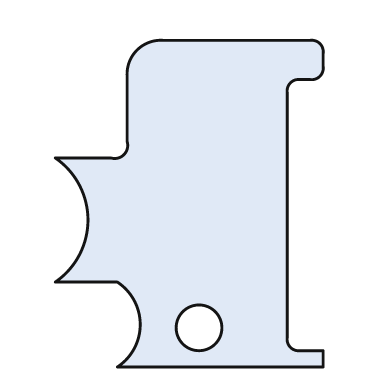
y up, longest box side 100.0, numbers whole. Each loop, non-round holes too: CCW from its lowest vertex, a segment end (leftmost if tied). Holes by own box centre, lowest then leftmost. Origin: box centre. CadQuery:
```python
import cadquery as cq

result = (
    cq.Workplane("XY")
    .moveTo(-22.0, -50.0)
    .lineTo(41.0, -50.0)
    .lineTo(41.0, -45.0)
    .lineTo(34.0, -45.0)
    .threePointArc((31.0, -44.0), (30.0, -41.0))
    .lineTo(30.0, 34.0)
    .threePointArc((31.0, 37.0), (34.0, 38.0))
    .lineTo(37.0, 38.0)
    .threePointArc((40.0, 39.0), (41.0, 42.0))
    .lineTo(41.0, 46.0)
    .threePointArc((40.0, 49.0), (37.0, 50.0))
    .lineTo(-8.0, 50.0)
    .threePointArc((-16.0, 47.0), (-19.0, 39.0))
    .lineTo(-19.0, 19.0)
    .threePointArc((-20.0, 15.0), (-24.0, 14.0))
    .lineTo(-41.0, 14.0)
    .threePointArc((-31.0, -5.0), (-41.0, -24.0))
    .lineTo(-22.0, -24.0)
    .threePointArc((-15.0, -37.0), (-22.0, -50.0))
    .close()
    .moveTo(3.0, -38.0)
    .circle(7.0)
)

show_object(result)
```